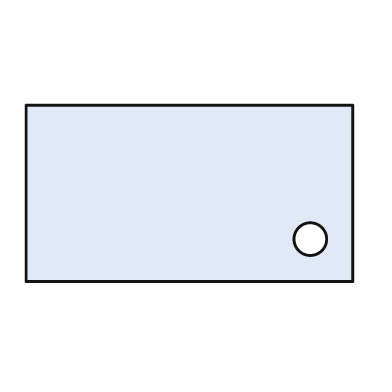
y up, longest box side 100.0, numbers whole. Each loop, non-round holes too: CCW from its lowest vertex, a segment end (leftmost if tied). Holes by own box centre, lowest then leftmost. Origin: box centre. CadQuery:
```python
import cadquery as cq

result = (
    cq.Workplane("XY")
    .moveTo(-50.0, -27.0)
    .lineTo(50.0, -27.0)
    .lineTo(50.0, 27.0)
    .lineTo(-50.0, 27.0)
    .close()
    .moveTo(37.0, -14.0)
    .circle(5.0)
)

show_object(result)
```